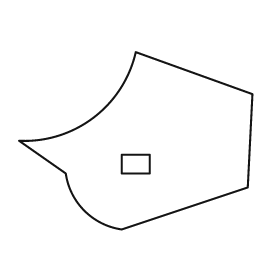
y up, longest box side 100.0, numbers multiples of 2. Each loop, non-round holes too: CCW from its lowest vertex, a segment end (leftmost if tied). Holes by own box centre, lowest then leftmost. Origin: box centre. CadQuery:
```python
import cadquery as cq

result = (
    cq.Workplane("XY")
    .moveTo(-6.0, -38.0)
    .lineTo(48.0, -20.0)
    .lineTo(50.0, 20.0)
    .lineTo(0.0, 38.0)
    .threePointArc((-18.0, 10.0), (-50.0, 0.0))
    .lineTo(-30.0, -14.0)
    .threePointArc((-22.0, -30.0), (-6.0, -38.0))
    .close()
    .moveTo(-6.0, -14.0)
    .lineTo(6.0, -14.0)
    .lineTo(6.0, -6.0)
    .lineTo(-6.0, -6.0)
    .close()
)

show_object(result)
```